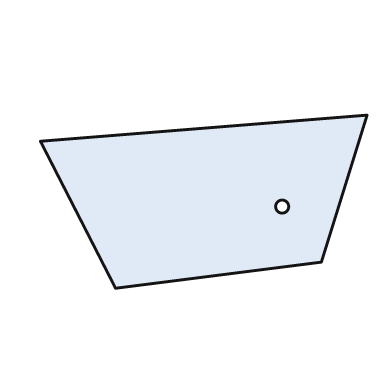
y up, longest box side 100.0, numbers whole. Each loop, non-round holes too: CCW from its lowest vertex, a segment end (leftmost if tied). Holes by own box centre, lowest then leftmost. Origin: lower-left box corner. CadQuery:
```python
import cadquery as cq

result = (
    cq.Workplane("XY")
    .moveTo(23.0, 0.0)
    .lineTo(86.0, 8.0)
    .lineTo(100.0, 53.0)
    .lineTo(0.0, 45.0)
    .close()
    .moveTo(74.0, 25.0)
    .circle(2.0)
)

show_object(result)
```